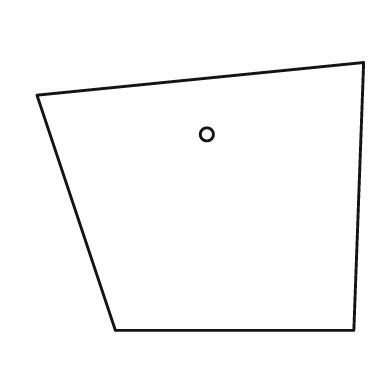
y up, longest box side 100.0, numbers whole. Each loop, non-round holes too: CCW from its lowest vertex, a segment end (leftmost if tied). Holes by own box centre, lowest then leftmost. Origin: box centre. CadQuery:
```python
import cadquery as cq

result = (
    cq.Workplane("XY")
    .moveTo(-26.0, -41.0)
    .lineTo(47.0, -41.0)
    .lineTo(50.0, 41.0)
    .lineTo(-50.0, 31.0)
    .close()
    .moveTo(2.0, 19.0)
    .circle(2.0)
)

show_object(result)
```